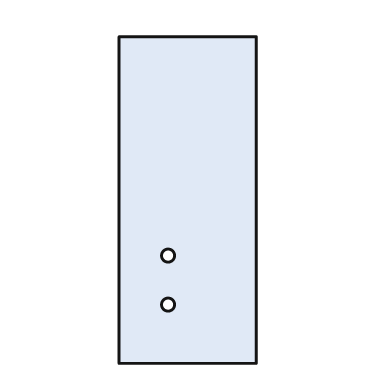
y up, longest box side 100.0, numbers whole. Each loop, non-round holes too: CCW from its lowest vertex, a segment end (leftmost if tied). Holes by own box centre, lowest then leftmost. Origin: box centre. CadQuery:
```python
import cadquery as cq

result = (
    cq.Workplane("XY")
    .moveTo(-21.0, -50.0)
    .lineTo(21.0, -50.0)
    .lineTo(21.0, 50.0)
    .lineTo(-21.0, 50.0)
    .close()
    .moveTo(-6.0, -32.0)
    .circle(2.0)
    .moveTo(-6.0, -17.0)
    .circle(2.0)
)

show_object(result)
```